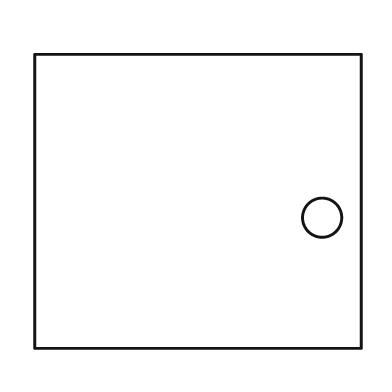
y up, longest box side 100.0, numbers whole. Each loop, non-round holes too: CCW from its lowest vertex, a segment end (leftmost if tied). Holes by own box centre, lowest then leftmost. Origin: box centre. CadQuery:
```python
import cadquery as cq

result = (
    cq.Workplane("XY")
    .moveTo(-50.0, -45.0)
    .lineTo(50.0, -45.0)
    .lineTo(50.0, 45.0)
    .lineTo(-50.0, 45.0)
    .close()
    .moveTo(38.0, -5.0)
    .circle(6.0)
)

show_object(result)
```